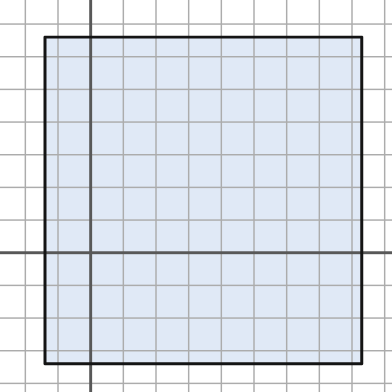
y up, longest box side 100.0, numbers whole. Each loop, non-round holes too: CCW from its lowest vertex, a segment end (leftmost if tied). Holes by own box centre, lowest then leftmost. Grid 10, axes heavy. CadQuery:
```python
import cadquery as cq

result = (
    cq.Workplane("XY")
    .moveTo(-14.0, -34.0)
    .lineTo(83.0, -34.0)
    .lineTo(83.0, 66.0)
    .lineTo(-14.0, 66.0)
    .close()
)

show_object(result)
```